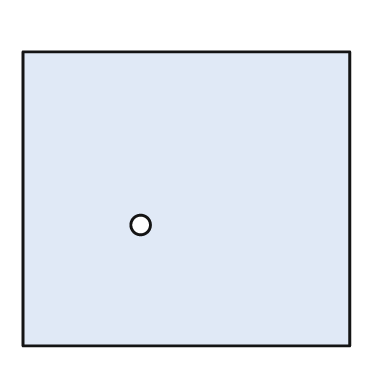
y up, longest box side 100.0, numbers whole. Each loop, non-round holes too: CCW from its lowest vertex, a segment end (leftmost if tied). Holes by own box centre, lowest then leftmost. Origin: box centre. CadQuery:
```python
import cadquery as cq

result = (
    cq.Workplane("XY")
    .moveTo(-50.0, -45.0)
    .lineTo(50.0, -45.0)
    .lineTo(50.0, 45.0)
    .lineTo(-50.0, 45.0)
    .close()
    .moveTo(-14.0, -8.0)
    .circle(3.0)
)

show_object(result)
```